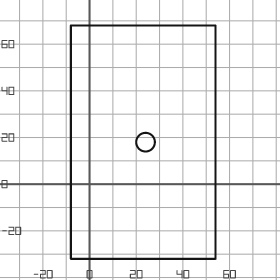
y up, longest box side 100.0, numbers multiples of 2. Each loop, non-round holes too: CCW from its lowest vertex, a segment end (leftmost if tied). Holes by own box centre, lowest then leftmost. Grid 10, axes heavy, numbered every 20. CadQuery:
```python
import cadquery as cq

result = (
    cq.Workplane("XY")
    .moveTo(-8.0, -32.0)
    .lineTo(54.0, -32.0)
    .lineTo(54.0, 68.0)
    .lineTo(-8.0, 68.0)
    .close()
    .moveTo(24.0, 18.0)
    .circle(4.0)
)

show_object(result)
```